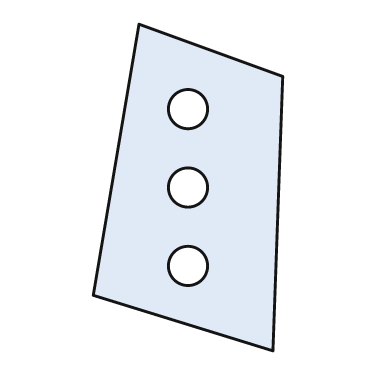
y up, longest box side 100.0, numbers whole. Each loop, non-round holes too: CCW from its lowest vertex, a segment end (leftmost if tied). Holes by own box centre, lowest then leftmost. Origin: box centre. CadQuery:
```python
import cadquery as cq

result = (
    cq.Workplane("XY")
    .moveTo(26.0, -50.0)
    .lineTo(29.0, 34.0)
    .lineTo(-15.0, 50.0)
    .lineTo(-29.0, -33.0)
    .close()
    .moveTo(0.0, -24.0)
    .circle(6.0)
    .moveTo(0.0, 0.0)
    .circle(6.0)
    .moveTo(0.0, 24.0)
    .circle(6.0)
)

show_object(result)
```